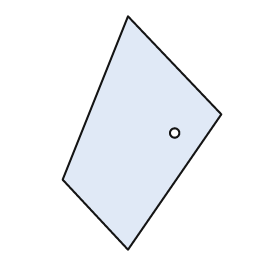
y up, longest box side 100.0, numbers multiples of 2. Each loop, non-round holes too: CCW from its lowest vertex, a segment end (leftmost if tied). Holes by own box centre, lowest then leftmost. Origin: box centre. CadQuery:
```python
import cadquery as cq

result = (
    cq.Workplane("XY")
    .moveTo(-6.0, -50.0)
    .lineTo(34.0, 8.0)
    .lineTo(-6.0, 50.0)
    .lineTo(-34.0, -20.0)
    .close()
    .moveTo(14.0, 0.0)
    .circle(2.0)
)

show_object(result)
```